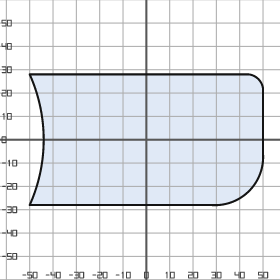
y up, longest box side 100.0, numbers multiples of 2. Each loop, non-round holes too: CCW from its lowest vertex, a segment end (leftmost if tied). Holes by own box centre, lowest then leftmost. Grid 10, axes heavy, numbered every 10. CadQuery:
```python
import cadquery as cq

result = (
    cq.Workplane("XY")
    .moveTo(-50.0, -28.0)
    .lineTo(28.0, -28.0)
    .threePointArc((44.0, -22.0), (50.0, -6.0))
    .lineTo(50.0, 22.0)
    .threePointArc((48.0, 26.0), (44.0, 28.0))
    .lineTo(-50.0, 28.0)
    .threePointArc((-44.0, 0.0), (-50.0, -28.0))
    .close()
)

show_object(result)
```